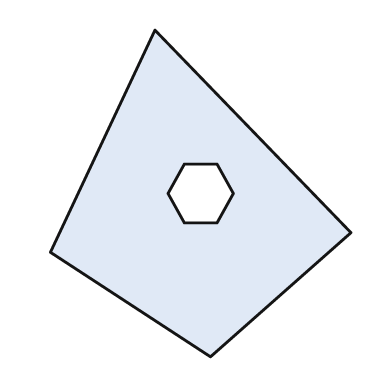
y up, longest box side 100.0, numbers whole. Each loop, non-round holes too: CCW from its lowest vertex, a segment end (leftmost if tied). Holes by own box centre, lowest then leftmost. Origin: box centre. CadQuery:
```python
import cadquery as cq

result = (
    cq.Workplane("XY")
    .moveTo(3.0, -50.0)
    .lineTo(46.0, -12.0)
    .lineTo(-14.0, 50.0)
    .lineTo(-46.0, -18.0)
    .close()
    .moveTo(-5.0, -9.0)
    .lineTo(5.0, -9.0)
    .lineTo(10.0, 0.0)
    .lineTo(5.0, 9.0)
    .lineTo(-5.0, 9.0)
    .lineTo(-10.0, 0.0)
    .close()
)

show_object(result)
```